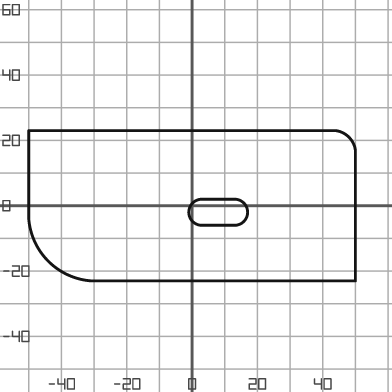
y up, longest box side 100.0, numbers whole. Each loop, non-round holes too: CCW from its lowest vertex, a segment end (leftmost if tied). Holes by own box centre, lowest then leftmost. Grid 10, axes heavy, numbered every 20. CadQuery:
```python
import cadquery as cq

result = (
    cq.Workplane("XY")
    .moveTo(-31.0, -23.0)
    .lineTo(50.0, -23.0)
    .lineTo(50.0, 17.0)
    .threePointArc((48.0, 21.0), (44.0, 23.0))
    .lineTo(-50.0, 23.0)
    .lineTo(-50.0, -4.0)
    .threePointArc((-44.0, -17.0), (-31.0, -23.0))
    .close()
    .moveTo(3.0, -6.0)
    .lineTo(13.0, -6.0)
    .threePointArc((17.0, -2.0), (13.0, 2.0))
    .lineTo(3.0, 2.0)
    .threePointArc((-1.0, -2.0), (3.0, -6.0))
    .close()
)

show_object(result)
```